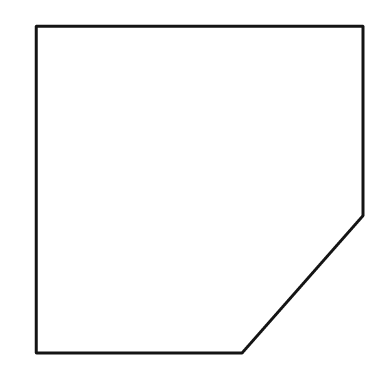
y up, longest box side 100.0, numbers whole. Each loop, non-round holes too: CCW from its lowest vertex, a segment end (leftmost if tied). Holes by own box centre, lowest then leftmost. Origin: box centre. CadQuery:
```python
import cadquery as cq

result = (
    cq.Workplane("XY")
    .moveTo(-50.0, -50.0)
    .lineTo(13.0, -50.0)
    .lineTo(50.0, -8.0)
    .lineTo(50.0, 50.0)
    .lineTo(-50.0, 50.0)
    .close()
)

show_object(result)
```